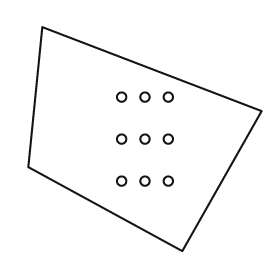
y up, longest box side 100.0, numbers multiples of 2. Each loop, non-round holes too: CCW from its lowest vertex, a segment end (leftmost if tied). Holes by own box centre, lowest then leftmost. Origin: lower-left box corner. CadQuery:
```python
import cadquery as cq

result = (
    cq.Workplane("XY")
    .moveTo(66.0, 0.0)
    .lineTo(100.0, 60.0)
    .lineTo(6.0, 96.0)
    .lineTo(0.0, 36.0)
    .close()
    .moveTo(40.0, 30.0)
    .circle(2.0)
    .moveTo(50.0, 30.0)
    .circle(2.0)
    .moveTo(60.0, 30.0)
    .circle(2.0)
    .moveTo(40.0, 48.0)
    .circle(2.0)
    .moveTo(50.0, 48.0)
    .circle(2.0)
    .moveTo(60.0, 48.0)
    .circle(2.0)
    .moveTo(40.0, 66.0)
    .circle(2.0)
    .moveTo(50.0, 66.0)
    .circle(2.0)
    .moveTo(60.0, 66.0)
    .circle(2.0)
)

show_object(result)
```